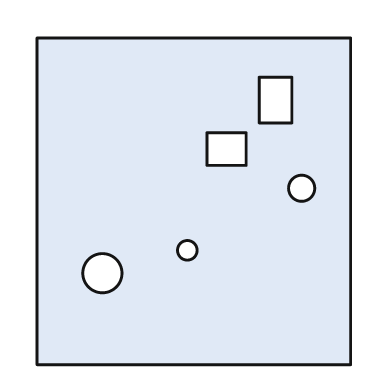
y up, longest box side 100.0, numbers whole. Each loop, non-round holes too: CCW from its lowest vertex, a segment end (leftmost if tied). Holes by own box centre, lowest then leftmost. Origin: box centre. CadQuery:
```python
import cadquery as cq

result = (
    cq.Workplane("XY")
    .moveTo(-48.0, -50.0)
    .lineTo(48.0, -50.0)
    .lineTo(48.0, 50.0)
    .lineTo(-48.0, 50.0)
    .close()
    .moveTo(-28.0, -22.0)
    .circle(6.0)
    .moveTo(-2.0, -15.0)
    .circle(3.0)
    .moveTo(33.0, 4.0)
    .circle(4.0)
    .moveTo(4.0, 11.0)
    .lineTo(16.0, 11.0)
    .lineTo(16.0, 21.0)
    .lineTo(4.0, 21.0)
    .close()
    .moveTo(20.0, 24.0)
    .lineTo(30.0, 24.0)
    .lineTo(30.0, 38.0)
    .lineTo(20.0, 38.0)
    .close()
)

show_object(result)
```